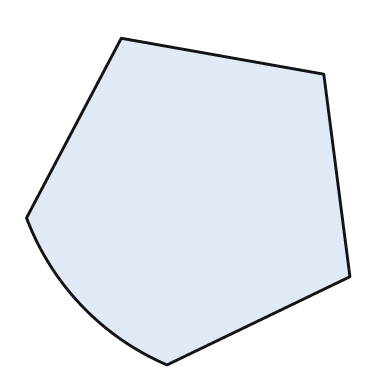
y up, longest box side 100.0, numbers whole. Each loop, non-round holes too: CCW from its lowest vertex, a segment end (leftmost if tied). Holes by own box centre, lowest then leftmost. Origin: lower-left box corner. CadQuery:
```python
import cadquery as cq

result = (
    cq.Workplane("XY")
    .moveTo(43.0, 0.0)
    .lineTo(99.0, 27.0)
    .lineTo(91.0, 89.0)
    .lineTo(29.0, 100.0)
    .lineTo(0.0, 45.0)
    .threePointArc((17.0, 18.0), (43.0, 0.0))
    .close()
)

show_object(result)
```